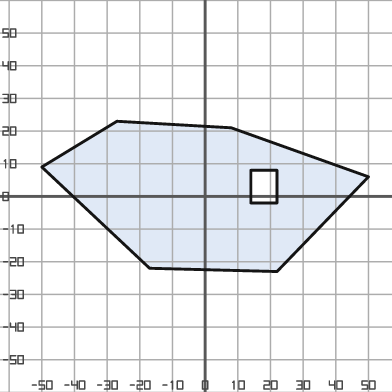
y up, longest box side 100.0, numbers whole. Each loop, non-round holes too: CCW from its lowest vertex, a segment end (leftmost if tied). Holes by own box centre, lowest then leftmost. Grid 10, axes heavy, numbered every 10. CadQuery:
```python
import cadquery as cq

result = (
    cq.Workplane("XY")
    .moveTo(22.0, -23.0)
    .lineTo(50.0, 6.0)
    .lineTo(8.0, 21.0)
    .lineTo(-27.0, 23.0)
    .lineTo(-50.0, 9.0)
    .lineTo(-17.0, -22.0)
    .close()
    .moveTo(14.0, -2.0)
    .lineTo(22.0, -2.0)
    .lineTo(22.0, 8.0)
    .lineTo(14.0, 8.0)
    .close()
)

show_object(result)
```